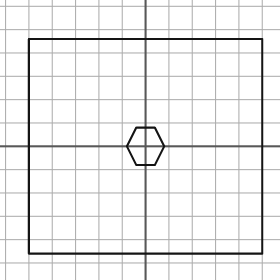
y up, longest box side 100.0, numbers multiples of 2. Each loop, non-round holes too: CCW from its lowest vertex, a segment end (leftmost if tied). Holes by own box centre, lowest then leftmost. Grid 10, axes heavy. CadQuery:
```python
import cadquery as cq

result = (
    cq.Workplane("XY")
    .moveTo(-50.0, -46.0)
    .lineTo(50.0, -46.0)
    .lineTo(50.0, 46.0)
    .lineTo(-50.0, 46.0)
    .close()
    .moveTo(-4.0, -8.0)
    .lineTo(4.0, -8.0)
    .lineTo(8.0, 0.0)
    .lineTo(4.0, 8.0)
    .lineTo(-4.0, 8.0)
    .lineTo(-8.0, 0.0)
    .close()
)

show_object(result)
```